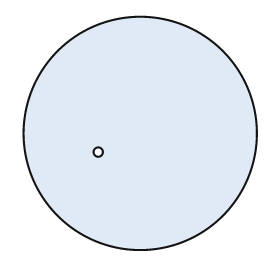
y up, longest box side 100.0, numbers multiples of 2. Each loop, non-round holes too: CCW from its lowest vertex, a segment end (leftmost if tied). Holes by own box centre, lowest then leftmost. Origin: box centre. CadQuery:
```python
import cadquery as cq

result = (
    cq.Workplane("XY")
    .moveTo(0.0, 0.0)
    .circle(50.0)
    .moveTo(-18.0, -8.0)
    .circle(2.0)
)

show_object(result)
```